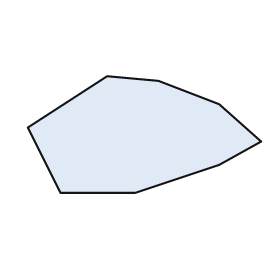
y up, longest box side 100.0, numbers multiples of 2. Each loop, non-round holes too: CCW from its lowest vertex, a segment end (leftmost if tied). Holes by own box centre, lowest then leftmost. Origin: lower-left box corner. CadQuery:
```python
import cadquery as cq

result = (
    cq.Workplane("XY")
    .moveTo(14.0, 0.0)
    .lineTo(46.0, 0.0)
    .lineTo(82.0, 12.0)
    .lineTo(100.0, 22.0)
    .lineTo(82.0, 38.0)
    .lineTo(56.0, 48.0)
    .lineTo(34.0, 50.0)
    .lineTo(0.0, 28.0)
    .close()
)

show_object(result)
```